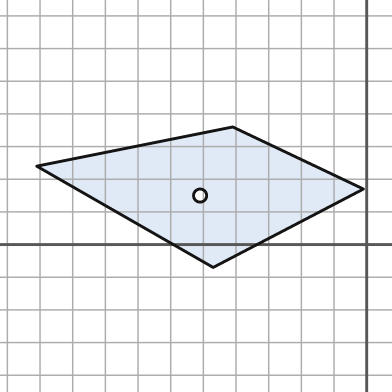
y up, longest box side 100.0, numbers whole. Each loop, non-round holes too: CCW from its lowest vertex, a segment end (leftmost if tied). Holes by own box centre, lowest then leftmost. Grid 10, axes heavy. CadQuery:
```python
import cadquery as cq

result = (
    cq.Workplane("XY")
    .moveTo(-47.0, -7.0)
    .lineTo(-1.0, 17.0)
    .lineTo(-41.0, 36.0)
    .lineTo(-101.0, 24.0)
    .close()
    .moveTo(-51.0, 15.0)
    .circle(2.0)
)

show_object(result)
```